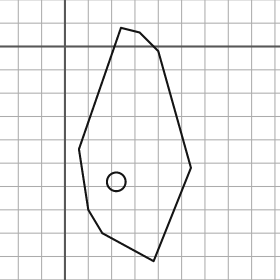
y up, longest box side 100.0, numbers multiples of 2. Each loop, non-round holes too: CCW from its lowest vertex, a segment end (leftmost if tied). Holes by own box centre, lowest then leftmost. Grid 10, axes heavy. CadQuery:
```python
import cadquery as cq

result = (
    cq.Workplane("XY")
    .moveTo(38.0, -92.0)
    .lineTo(54.0, -52.0)
    .lineTo(40.0, -2.0)
    .lineTo(32.0, 6.0)
    .lineTo(24.0, 8.0)
    .lineTo(6.0, -44.0)
    .lineTo(10.0, -70.0)
    .lineTo(16.0, -80.0)
    .close()
    .moveTo(22.0, -58.0)
    .circle(4.0)
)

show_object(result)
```